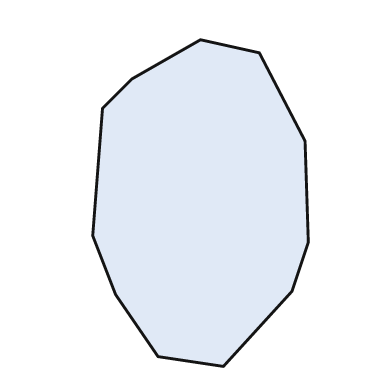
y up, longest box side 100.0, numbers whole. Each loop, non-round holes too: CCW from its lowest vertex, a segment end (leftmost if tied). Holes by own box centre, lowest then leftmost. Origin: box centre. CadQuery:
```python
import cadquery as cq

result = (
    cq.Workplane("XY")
    .moveTo(7.0, -50.0)
    .lineTo(28.0, -27.0)
    .lineTo(33.0, -12.0)
    .lineTo(32.0, 19.0)
    .lineTo(18.0, 46.0)
    .lineTo(0.0, 50.0)
    .lineTo(-21.0, 38.0)
    .lineTo(-30.0, 29.0)
    .lineTo(-33.0, -10.0)
    .lineTo(-26.0, -28.0)
    .lineTo(-13.0, -47.0)
    .close()
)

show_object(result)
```